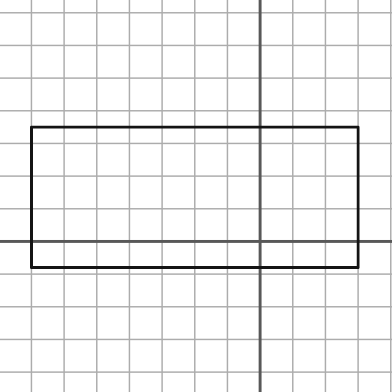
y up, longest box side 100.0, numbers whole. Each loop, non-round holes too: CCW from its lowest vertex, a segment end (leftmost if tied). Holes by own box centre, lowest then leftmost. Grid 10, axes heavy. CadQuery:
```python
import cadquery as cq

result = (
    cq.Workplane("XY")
    .moveTo(-70.0, -8.0)
    .lineTo(30.0, -8.0)
    .lineTo(30.0, 35.0)
    .lineTo(-70.0, 35.0)
    .close()
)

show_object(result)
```